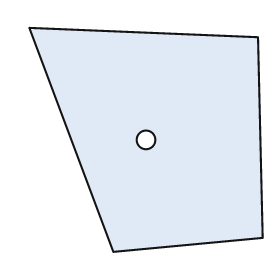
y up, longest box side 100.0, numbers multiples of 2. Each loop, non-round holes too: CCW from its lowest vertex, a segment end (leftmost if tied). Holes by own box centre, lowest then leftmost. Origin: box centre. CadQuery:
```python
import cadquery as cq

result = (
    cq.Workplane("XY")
    .moveTo(-14.0, -48.0)
    .lineTo(50.0, -42.0)
    .lineTo(48.0, 44.0)
    .lineTo(-50.0, 48.0)
    .close()
    .moveTo(0.0, 0.0)
    .circle(4.0)
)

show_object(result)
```